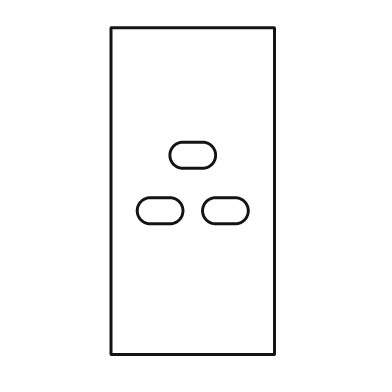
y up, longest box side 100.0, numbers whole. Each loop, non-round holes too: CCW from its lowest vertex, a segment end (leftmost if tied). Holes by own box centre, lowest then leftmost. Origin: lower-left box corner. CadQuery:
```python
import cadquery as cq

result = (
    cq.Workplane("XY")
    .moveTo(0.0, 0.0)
    .lineTo(50.0, 0.0)
    .lineTo(50.0, 100.0)
    .lineTo(0.0, 100.0)
    .close()
    .moveTo(12.0, 40.0)
    .lineTo(18.0, 40.0)
    .threePointArc((22.0, 44.0), (18.0, 48.0))
    .lineTo(12.0, 48.0)
    .threePointArc((8.0, 44.0), (12.0, 40.0))
    .close()
    .moveTo(32.0, 40.0)
    .lineTo(38.0, 40.0)
    .threePointArc((42.0, 44.0), (38.0, 48.0))
    .lineTo(32.0, 48.0)
    .threePointArc((28.0, 44.0), (32.0, 40.0))
    .close()
    .moveTo(22.0, 57.0)
    .lineTo(28.0, 57.0)
    .threePointArc((32.0, 61.0), (28.0, 65.0))
    .lineTo(22.0, 65.0)
    .threePointArc((18.0, 61.0), (22.0, 57.0))
    .close()
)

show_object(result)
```